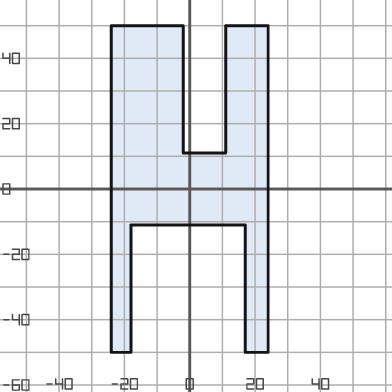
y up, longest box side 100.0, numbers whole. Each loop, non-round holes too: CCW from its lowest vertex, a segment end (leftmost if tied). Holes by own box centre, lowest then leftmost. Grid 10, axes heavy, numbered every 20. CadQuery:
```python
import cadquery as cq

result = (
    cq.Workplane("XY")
    .moveTo(-24.0, -50.0)
    .lineTo(-18.0, -50.0)
    .lineTo(-18.0, -11.0)
    .lineTo(17.0, -11.0)
    .lineTo(17.0, -50.0)
    .lineTo(24.0, -50.0)
    .lineTo(24.0, 50.0)
    .lineTo(11.0, 50.0)
    .lineTo(11.0, 11.0)
    .lineTo(-2.0, 11.0)
    .lineTo(-2.0, 50.0)
    .lineTo(-24.0, 50.0)
    .close()
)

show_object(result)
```